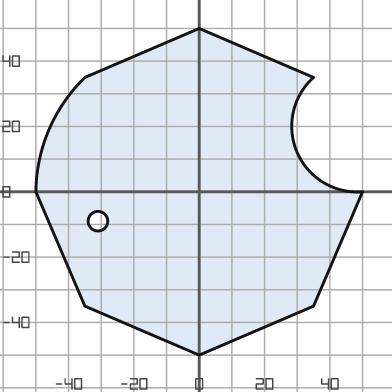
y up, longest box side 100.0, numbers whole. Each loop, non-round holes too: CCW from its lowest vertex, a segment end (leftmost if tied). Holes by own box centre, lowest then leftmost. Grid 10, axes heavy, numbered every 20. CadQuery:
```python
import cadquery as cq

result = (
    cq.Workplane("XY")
    .moveTo(0.0, -50.0)
    .lineTo(35.0, -35.0)
    .lineTo(50.0, 0.0)
    .threePointArc((30.0, 12.0), (35.0, 35.0))
    .lineTo(0.0, 50.0)
    .lineTo(-35.0, 35.0)
    .threePointArc((-46.0, 19.0), (-50.0, 0.0))
    .lineTo(-35.0, -35.0)
    .close()
    .moveTo(-31.0, -9.0)
    .circle(3.0)
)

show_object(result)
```